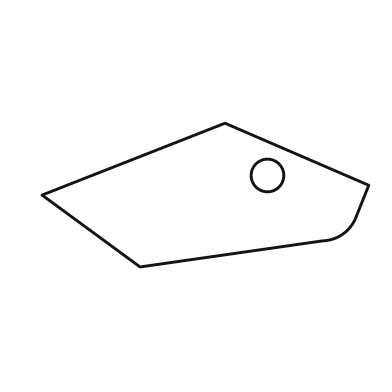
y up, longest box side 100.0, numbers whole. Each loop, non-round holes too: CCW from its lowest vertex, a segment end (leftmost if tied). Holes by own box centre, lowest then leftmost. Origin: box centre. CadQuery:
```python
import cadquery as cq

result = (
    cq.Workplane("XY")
    .moveTo(-20.0, -22.0)
    .lineTo(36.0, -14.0)
    .threePointArc((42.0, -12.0), (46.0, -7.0))
    .lineTo(50.0, 3.0)
    .lineTo(6.0, 22.0)
    .lineTo(-50.0, 0.0)
    .close()
    .moveTo(19.0, 6.0)
    .circle(5.0)
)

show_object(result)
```